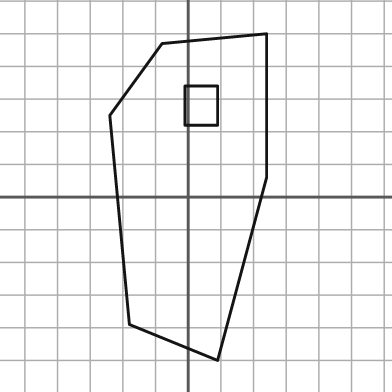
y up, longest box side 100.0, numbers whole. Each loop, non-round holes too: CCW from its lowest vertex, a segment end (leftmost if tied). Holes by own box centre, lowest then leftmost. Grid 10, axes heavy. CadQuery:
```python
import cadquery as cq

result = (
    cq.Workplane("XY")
    .moveTo(9.0, -50.0)
    .lineTo(24.0, 6.0)
    .lineTo(24.0, 50.0)
    .lineTo(-8.0, 47.0)
    .lineTo(-24.0, 25.0)
    .lineTo(-18.0, -39.0)
    .close()
    .moveTo(-1.0, 22.0)
    .lineTo(9.0, 22.0)
    .lineTo(9.0, 34.0)
    .lineTo(-1.0, 34.0)
    .close()
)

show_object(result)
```